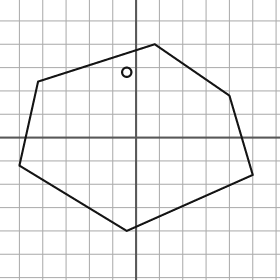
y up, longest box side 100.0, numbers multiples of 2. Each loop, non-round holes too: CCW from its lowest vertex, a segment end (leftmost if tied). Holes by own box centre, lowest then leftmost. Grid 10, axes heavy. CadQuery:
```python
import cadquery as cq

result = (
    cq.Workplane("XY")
    .moveTo(-4.0, -40.0)
    .lineTo(50.0, -16.0)
    .lineTo(40.0, 18.0)
    .lineTo(8.0, 40.0)
    .lineTo(-42.0, 24.0)
    .lineTo(-50.0, -12.0)
    .close()
    .moveTo(-4.0, 28.0)
    .circle(2.0)
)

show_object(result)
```